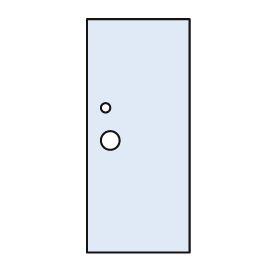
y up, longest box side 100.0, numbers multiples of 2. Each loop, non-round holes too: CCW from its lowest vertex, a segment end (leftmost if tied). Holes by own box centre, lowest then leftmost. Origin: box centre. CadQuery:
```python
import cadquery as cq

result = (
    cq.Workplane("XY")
    .moveTo(-22.0, -50.0)
    .lineTo(22.0, -50.0)
    .lineTo(22.0, 50.0)
    .lineTo(-22.0, 50.0)
    .close()
    .moveTo(-12.0, -2.0)
    .circle(4.0)
    .moveTo(-14.0, 12.0)
    .circle(2.0)
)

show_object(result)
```